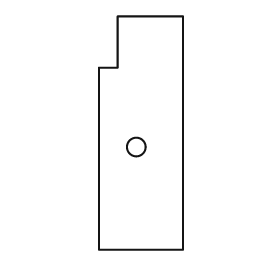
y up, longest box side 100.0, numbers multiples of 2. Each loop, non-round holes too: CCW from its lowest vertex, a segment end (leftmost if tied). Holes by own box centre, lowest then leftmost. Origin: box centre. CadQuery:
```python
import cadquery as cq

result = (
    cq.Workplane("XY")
    .moveTo(-18.0, -50.0)
    .lineTo(18.0, -50.0)
    .lineTo(18.0, 50.0)
    .lineTo(-10.0, 50.0)
    .lineTo(-10.0, 28.0)
    .lineTo(-18.0, 28.0)
    .close()
    .moveTo(-2.0, -6.0)
    .circle(4.0)
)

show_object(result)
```